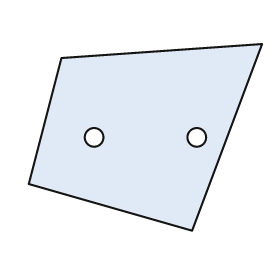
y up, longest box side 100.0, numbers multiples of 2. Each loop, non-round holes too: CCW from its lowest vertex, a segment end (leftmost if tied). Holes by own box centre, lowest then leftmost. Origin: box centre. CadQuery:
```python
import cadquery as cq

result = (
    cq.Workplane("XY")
    .moveTo(20.0, -40.0)
    .lineTo(50.0, 40.0)
    .lineTo(-36.0, 34.0)
    .lineTo(-50.0, -20.0)
    .close()
    .moveTo(-22.0, 0.0)
    .circle(4.0)
    .moveTo(22.0, 0.0)
    .circle(4.0)
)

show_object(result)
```